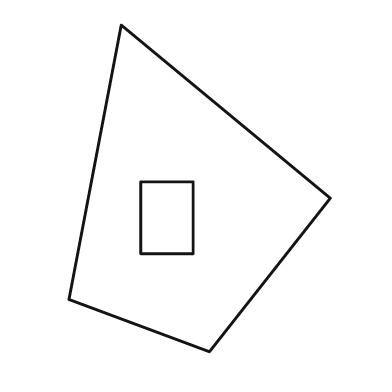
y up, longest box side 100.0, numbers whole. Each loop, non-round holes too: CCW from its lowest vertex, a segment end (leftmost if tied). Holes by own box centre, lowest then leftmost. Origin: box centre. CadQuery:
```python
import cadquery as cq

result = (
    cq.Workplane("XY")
    .moveTo(3.0, -50.0)
    .lineTo(40.0, -3.0)
    .lineTo(-24.0, 50.0)
    .lineTo(-40.0, -34.0)
    .close()
    .moveTo(-18.0, -20.0)
    .lineTo(-2.0, -20.0)
    .lineTo(-2.0, 2.0)
    .lineTo(-18.0, 2.0)
    .close()
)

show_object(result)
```